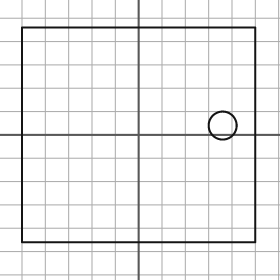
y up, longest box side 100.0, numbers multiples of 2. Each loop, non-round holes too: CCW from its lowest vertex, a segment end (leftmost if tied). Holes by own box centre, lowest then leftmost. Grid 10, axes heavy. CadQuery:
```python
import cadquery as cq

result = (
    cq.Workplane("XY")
    .moveTo(-50.0, -46.0)
    .lineTo(50.0, -46.0)
    .lineTo(50.0, 46.0)
    .lineTo(-50.0, 46.0)
    .close()
    .moveTo(36.0, 4.0)
    .circle(6.0)
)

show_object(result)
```